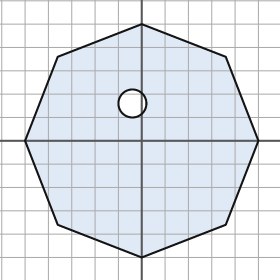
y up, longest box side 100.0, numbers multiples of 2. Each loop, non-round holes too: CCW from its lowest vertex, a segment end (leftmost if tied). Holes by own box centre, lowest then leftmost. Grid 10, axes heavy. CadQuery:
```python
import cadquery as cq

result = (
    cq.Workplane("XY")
    .moveTo(0.0, -50.0)
    .lineTo(36.0, -36.0)
    .lineTo(50.0, 0.0)
    .lineTo(36.0, 36.0)
    .lineTo(0.0, 50.0)
    .lineTo(-36.0, 36.0)
    .lineTo(-50.0, 0.0)
    .lineTo(-36.0, -36.0)
    .close()
    .moveTo(-4.0, 16.0)
    .circle(6.0)
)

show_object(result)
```